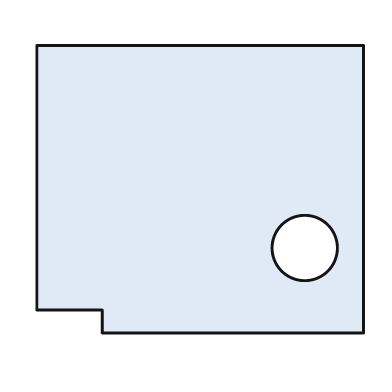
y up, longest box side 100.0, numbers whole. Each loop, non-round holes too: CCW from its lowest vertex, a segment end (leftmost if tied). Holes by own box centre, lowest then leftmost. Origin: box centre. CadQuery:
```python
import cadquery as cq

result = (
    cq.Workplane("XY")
    .moveTo(-30.0, -44.0)
    .lineTo(50.0, -44.0)
    .lineTo(50.0, 44.0)
    .lineTo(-50.0, 44.0)
    .lineTo(-50.0, -37.0)
    .lineTo(-30.0, -37.0)
    .close()
    .moveTo(32.0, -18.0)
    .circle(10.0)
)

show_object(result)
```